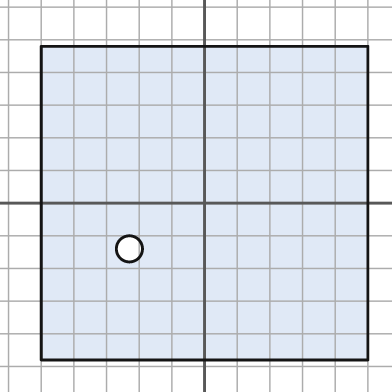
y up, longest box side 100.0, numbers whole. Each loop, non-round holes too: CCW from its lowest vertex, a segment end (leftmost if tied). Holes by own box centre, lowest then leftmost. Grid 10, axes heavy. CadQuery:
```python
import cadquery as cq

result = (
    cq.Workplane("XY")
    .moveTo(-50.0, -48.0)
    .lineTo(50.0, -48.0)
    .lineTo(50.0, 48.0)
    .lineTo(-50.0, 48.0)
    .close()
    .moveTo(-23.0, -14.0)
    .circle(4.0)
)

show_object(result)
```